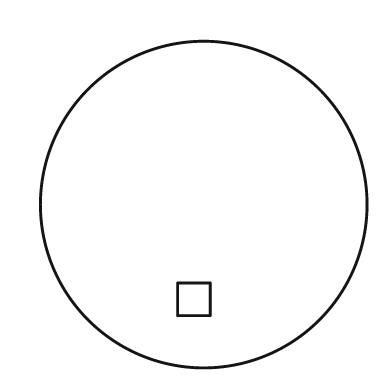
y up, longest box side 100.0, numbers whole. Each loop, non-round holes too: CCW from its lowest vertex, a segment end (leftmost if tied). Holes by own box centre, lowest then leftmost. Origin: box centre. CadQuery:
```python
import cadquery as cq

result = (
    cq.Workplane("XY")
    .moveTo(0.0, 0.0)
    .circle(50.0)
    .moveTo(-8.0, -34.0)
    .lineTo(2.0, -34.0)
    .lineTo(2.0, -24.0)
    .lineTo(-8.0, -24.0)
    .close()
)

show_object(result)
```